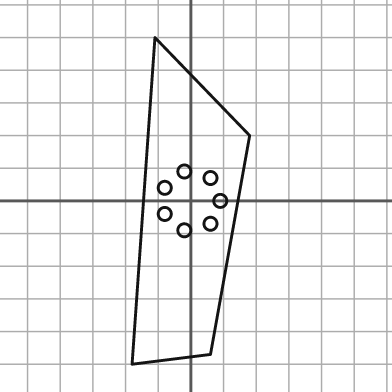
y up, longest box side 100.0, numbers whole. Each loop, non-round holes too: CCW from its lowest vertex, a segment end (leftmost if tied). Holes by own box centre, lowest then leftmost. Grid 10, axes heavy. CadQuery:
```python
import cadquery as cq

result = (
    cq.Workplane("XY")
    .moveTo(-18.0, -50.0)
    .lineTo(6.0, -47.0)
    .lineTo(18.0, 20.0)
    .lineTo(-11.0, 50.0)
    .close()
    .moveTo(-2.0, -9.0)
    .circle(2.0)
    .moveTo(6.0, -7.0)
    .circle(2.0)
    .moveTo(-8.0, -4.0)
    .circle(2.0)
    .moveTo(9.0, 0.0)
    .circle(2.0)
    .moveTo(-8.0, 4.0)
    .circle(2.0)
    .moveTo(6.0, 7.0)
    .circle(2.0)
    .moveTo(-2.0, 9.0)
    .circle(2.0)
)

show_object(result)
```